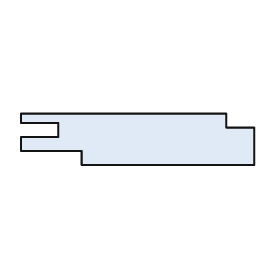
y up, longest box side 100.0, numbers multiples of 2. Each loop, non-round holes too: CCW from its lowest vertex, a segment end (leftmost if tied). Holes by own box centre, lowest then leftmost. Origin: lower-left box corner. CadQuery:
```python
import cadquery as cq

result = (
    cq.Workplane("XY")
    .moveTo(26.0, 0.0)
    .lineTo(100.0, 0.0)
    .lineTo(100.0, 16.0)
    .lineTo(88.0, 16.0)
    .lineTo(88.0, 22.0)
    .lineTo(0.0, 22.0)
    .lineTo(0.0, 18.0)
    .lineTo(16.0, 18.0)
    .lineTo(16.0, 12.0)
    .lineTo(0.0, 12.0)
    .lineTo(0.0, 6.0)
    .lineTo(26.0, 6.0)
    .close()
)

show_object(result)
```